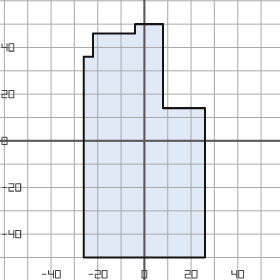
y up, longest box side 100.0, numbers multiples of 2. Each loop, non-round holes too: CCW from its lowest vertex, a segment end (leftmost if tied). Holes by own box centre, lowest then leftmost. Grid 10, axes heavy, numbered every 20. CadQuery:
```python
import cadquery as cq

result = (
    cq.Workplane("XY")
    .moveTo(-26.0, -50.0)
    .lineTo(26.0, -50.0)
    .lineTo(26.0, 14.0)
    .lineTo(8.0, 14.0)
    .lineTo(8.0, 50.0)
    .lineTo(-4.0, 50.0)
    .lineTo(-4.0, 46.0)
    .lineTo(-22.0, 46.0)
    .lineTo(-22.0, 36.0)
    .lineTo(-26.0, 36.0)
    .close()
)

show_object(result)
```